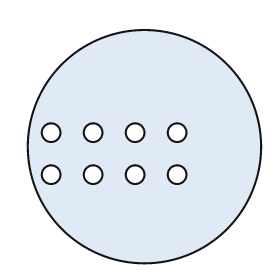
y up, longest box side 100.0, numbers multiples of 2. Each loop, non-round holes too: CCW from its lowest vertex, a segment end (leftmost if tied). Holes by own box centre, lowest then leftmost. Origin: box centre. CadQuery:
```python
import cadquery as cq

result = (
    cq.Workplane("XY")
    .moveTo(0.0, 0.0)
    .circle(50.0)
    .moveTo(-40.0, -12.0)
    .circle(4.0)
    .moveTo(-22.0, -12.0)
    .circle(4.0)
    .moveTo(-4.0, -12.0)
    .circle(4.0)
    .moveTo(14.0, -12.0)
    .circle(4.0)
    .moveTo(-40.0, 6.0)
    .circle(4.0)
    .moveTo(-22.0, 6.0)
    .circle(4.0)
    .moveTo(-4.0, 6.0)
    .circle(4.0)
    .moveTo(14.0, 6.0)
    .circle(4.0)
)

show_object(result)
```